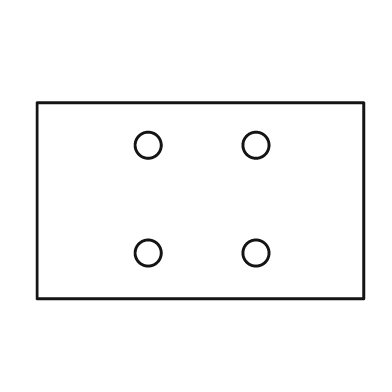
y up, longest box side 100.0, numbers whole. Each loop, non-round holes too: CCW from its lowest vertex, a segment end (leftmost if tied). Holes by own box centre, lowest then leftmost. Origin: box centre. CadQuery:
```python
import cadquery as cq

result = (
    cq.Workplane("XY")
    .moveTo(-50.0, -30.0)
    .lineTo(50.0, -30.0)
    .lineTo(50.0, 30.0)
    .lineTo(-50.0, 30.0)
    .close()
    .moveTo(-16.0, -16.0)
    .circle(4.0)
    .moveTo(17.0, -16.0)
    .circle(4.0)
    .moveTo(-16.0, 17.0)
    .circle(4.0)
    .moveTo(17.0, 17.0)
    .circle(4.0)
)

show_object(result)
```